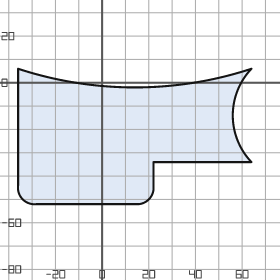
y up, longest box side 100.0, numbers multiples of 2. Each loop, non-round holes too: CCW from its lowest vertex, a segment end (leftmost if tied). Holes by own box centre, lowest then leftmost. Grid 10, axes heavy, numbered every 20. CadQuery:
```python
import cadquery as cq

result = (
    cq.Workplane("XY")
    .moveTo(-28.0, -52.0)
    .lineTo(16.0, -52.0)
    .threePointArc((20.0, -50.0), (22.0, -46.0))
    .lineTo(22.0, -34.0)
    .lineTo(64.0, -34.0)
    .threePointArc((56.0, -14.0), (64.0, 6.0))
    .threePointArc((14.0, -2.0), (-36.0, 6.0))
    .lineTo(-36.0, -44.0)
    .threePointArc((-34.0, -50.0), (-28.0, -52.0))
    .close()
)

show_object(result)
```